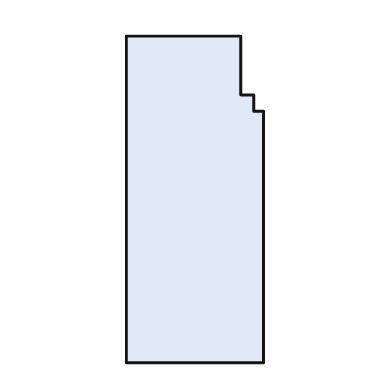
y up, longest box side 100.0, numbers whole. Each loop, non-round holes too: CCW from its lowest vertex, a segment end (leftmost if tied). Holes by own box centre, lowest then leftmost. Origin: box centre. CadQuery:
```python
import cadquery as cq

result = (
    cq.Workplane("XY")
    .moveTo(-21.0, -50.0)
    .lineTo(21.0, -50.0)
    .lineTo(21.0, 27.0)
    .lineTo(18.0, 27.0)
    .lineTo(18.0, 32.0)
    .lineTo(14.0, 32.0)
    .lineTo(14.0, 50.0)
    .lineTo(-21.0, 50.0)
    .close()
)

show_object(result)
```